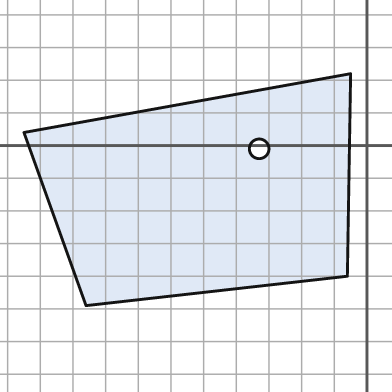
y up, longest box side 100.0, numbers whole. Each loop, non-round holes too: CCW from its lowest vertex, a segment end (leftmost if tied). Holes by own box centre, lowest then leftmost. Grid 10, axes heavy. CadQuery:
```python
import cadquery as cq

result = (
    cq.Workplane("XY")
    .moveTo(-86.0, -49.0)
    .lineTo(-6.0, -40.0)
    .lineTo(-5.0, 22.0)
    .lineTo(-105.0, 4.0)
    .close()
    .moveTo(-33.0, -1.0)
    .circle(3.0)
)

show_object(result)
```